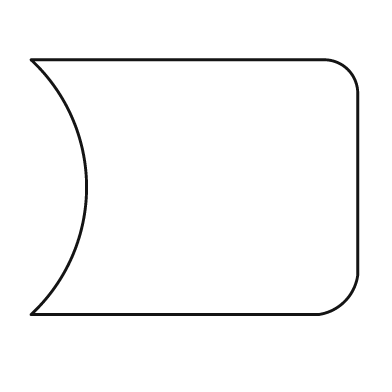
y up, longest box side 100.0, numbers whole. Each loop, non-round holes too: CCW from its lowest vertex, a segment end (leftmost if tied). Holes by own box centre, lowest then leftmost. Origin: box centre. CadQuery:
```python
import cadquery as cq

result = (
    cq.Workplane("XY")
    .moveTo(-50.0, -39.0)
    .lineTo(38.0, -39.0)
    .threePointArc((46.0, -35.0), (50.0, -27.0))
    .lineTo(50.0, 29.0)
    .threePointArc((47.0, 36.0), (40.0, 39.0))
    .lineTo(-50.0, 39.0)
    .threePointArc((-33.0, 0.0), (-50.0, -39.0))
    .close()
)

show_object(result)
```